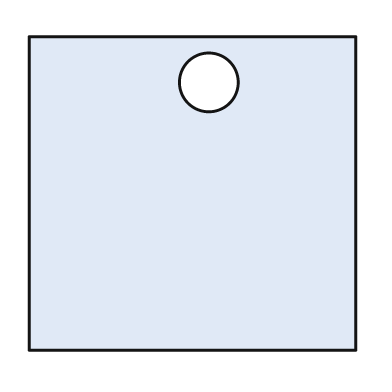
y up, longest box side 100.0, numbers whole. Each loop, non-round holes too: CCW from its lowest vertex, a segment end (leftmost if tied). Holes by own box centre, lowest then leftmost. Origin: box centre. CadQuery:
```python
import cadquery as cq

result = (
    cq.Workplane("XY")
    .moveTo(-50.0, -48.0)
    .lineTo(50.0, -48.0)
    .lineTo(50.0, 48.0)
    .lineTo(-50.0, 48.0)
    .close()
    .moveTo(5.0, 34.0)
    .circle(9.0)
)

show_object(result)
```